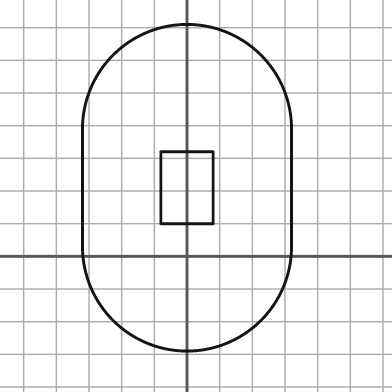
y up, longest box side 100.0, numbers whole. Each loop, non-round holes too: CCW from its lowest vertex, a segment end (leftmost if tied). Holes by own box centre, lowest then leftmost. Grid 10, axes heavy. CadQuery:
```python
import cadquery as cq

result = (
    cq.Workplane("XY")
    .moveTo(-32.0, 3.0)
    .threePointArc((0.0, -29.0), (32.0, 3.0))
    .lineTo(32.0, 39.0)
    .threePointArc((0.0, 71.0), (-32.0, 39.0))
    .close()
    .moveTo(-8.0, 10.0)
    .lineTo(8.0, 10.0)
    .lineTo(8.0, 32.0)
    .lineTo(-8.0, 32.0)
    .close()
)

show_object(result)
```